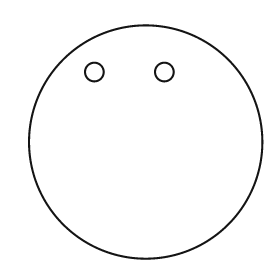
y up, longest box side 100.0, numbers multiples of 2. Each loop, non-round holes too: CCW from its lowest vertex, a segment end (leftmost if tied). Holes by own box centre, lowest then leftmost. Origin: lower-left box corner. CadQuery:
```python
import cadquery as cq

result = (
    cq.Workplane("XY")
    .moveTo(50.0, 50.0)
    .circle(50.0)
    .moveTo(28.0, 80.0)
    .circle(4.0)
    .moveTo(58.0, 80.0)
    .circle(4.0)
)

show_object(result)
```